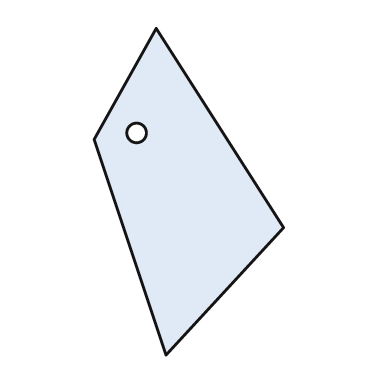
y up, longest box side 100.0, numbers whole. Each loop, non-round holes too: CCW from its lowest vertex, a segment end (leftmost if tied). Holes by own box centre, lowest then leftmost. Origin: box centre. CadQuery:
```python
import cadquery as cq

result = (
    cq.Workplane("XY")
    .moveTo(-7.0, -50.0)
    .lineTo(29.0, -11.0)
    .lineTo(-10.0, 50.0)
    .lineTo(-29.0, 16.0)
    .close()
    .moveTo(-16.0, 18.0)
    .circle(3.0)
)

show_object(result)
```